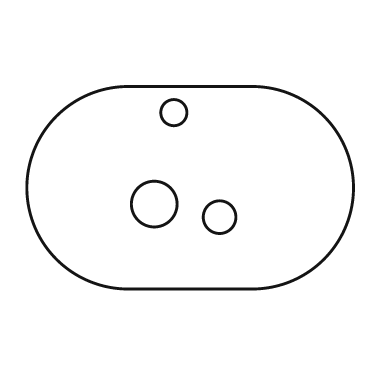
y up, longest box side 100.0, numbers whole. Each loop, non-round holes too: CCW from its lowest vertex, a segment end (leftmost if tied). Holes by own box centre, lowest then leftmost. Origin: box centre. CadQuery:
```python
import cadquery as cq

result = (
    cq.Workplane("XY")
    .moveTo(-19.0, -31.0)
    .lineTo(19.0, -31.0)
    .threePointArc((50.0, 0.0), (19.0, 31.0))
    .lineTo(-19.0, 31.0)
    .threePointArc((-50.0, 0.0), (-19.0, -31.0))
    .close()
    .moveTo(9.0, -9.0)
    .circle(5.0)
    .moveTo(-11.0, -5.0)
    .circle(7.0)
    .moveTo(-5.0, 23.0)
    .circle(4.0)
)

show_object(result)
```